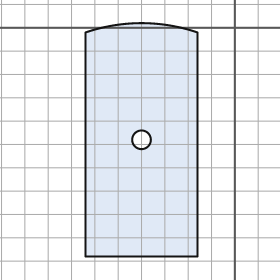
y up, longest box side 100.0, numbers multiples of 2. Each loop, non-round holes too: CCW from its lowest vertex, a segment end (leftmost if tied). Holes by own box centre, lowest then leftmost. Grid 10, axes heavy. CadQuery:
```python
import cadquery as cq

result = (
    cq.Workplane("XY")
    .moveTo(-64.0, -98.0)
    .lineTo(-16.0, -98.0)
    .lineTo(-16.0, -2.0)
    .threePointArc((-40.0, 2.0), (-64.0, -2.0))
    .close()
    .moveTo(-40.0, -48.0)
    .circle(4.0)
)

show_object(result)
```